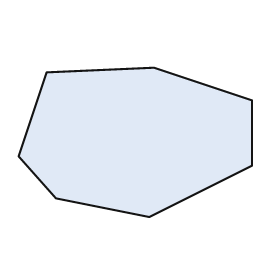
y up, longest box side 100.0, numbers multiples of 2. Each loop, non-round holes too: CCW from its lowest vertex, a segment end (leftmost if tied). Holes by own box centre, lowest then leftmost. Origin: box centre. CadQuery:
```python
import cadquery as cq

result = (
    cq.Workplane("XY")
    .moveTo(6.0, -32.0)
    .lineTo(50.0, -10.0)
    .lineTo(50.0, 18.0)
    .lineTo(8.0, 32.0)
    .lineTo(-38.0, 30.0)
    .lineTo(-50.0, -6.0)
    .lineTo(-34.0, -24.0)
    .close()
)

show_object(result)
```